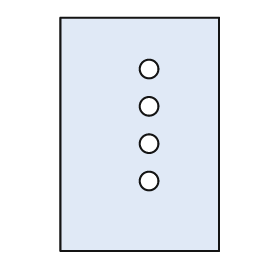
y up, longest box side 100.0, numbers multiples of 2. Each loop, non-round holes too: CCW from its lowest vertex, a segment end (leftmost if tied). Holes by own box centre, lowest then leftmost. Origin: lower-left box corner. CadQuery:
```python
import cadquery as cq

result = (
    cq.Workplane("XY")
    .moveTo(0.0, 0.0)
    .lineTo(68.0, 0.0)
    .lineTo(68.0, 100.0)
    .lineTo(0.0, 100.0)
    .close()
    .moveTo(38.0, 30.0)
    .circle(4.0)
    .moveTo(38.0, 46.0)
    .circle(4.0)
    .moveTo(38.0, 62.0)
    .circle(4.0)
    .moveTo(38.0, 78.0)
    .circle(4.0)
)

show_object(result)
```